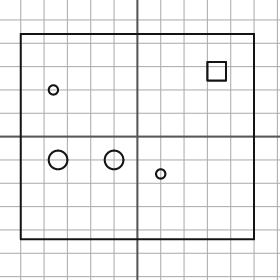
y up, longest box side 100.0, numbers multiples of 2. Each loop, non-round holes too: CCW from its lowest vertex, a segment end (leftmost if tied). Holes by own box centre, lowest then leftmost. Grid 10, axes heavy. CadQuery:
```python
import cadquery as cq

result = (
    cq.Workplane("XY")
    .moveTo(-50.0, -44.0)
    .lineTo(50.0, -44.0)
    .lineTo(50.0, 44.0)
    .lineTo(-50.0, 44.0)
    .close()
    .moveTo(10.0, -16.0)
    .circle(2.0)
    .moveTo(-34.0, -10.0)
    .circle(4.0)
    .moveTo(-10.0, -10.0)
    .circle(4.0)
    .moveTo(-36.0, 20.0)
    .circle(2.0)
    .moveTo(30.0, 24.0)
    .lineTo(38.0, 24.0)
    .lineTo(38.0, 32.0)
    .lineTo(30.0, 32.0)
    .close()
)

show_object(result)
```